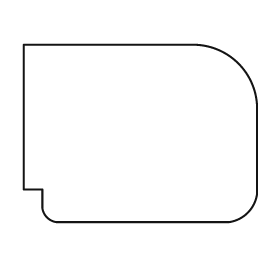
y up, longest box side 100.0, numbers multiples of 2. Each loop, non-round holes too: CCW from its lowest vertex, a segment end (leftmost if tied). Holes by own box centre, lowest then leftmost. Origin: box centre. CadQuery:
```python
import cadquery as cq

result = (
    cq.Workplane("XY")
    .moveTo(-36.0, -38.0)
    .lineTo(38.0, -38.0)
    .threePointArc((46.0, -34.0), (50.0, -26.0))
    .lineTo(50.0, 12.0)
    .threePointArc((42.0, 30.0), (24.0, 38.0))
    .lineTo(-50.0, 38.0)
    .lineTo(-50.0, -24.0)
    .lineTo(-42.0, -24.0)
    .lineTo(-42.0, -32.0)
    .threePointArc((-40.0, -36.0), (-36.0, -38.0))
    .close()
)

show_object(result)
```